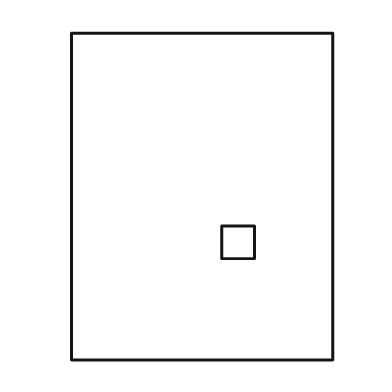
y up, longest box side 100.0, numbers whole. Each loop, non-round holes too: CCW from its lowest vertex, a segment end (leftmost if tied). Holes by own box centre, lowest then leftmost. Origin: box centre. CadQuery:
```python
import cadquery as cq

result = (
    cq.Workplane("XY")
    .moveTo(-40.0, -50.0)
    .lineTo(40.0, -50.0)
    .lineTo(40.0, 50.0)
    .lineTo(-40.0, 50.0)
    .close()
    .moveTo(6.0, -19.0)
    .lineTo(16.0, -19.0)
    .lineTo(16.0, -9.0)
    .lineTo(6.0, -9.0)
    .close()
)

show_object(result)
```